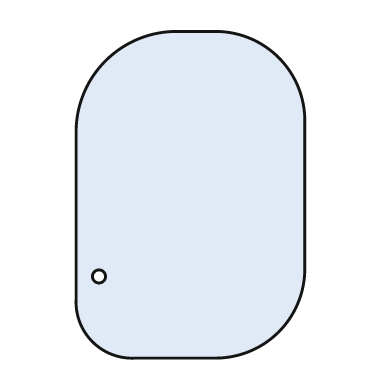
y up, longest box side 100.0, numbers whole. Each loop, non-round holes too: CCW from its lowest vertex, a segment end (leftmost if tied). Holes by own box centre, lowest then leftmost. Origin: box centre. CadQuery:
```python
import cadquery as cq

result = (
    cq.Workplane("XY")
    .moveTo(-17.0, -50.0)
    .lineTo(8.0, -50.0)
    .threePointArc((27.0, -42.0), (35.0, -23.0))
    .lineTo(35.0, 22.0)
    .threePointArc((27.0, 42.0), (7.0, 50.0))
    .lineTo(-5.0, 50.0)
    .threePointArc((-26.0, 41.0), (-35.0, 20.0))
    .lineTo(-35.0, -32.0)
    .threePointArc((-30.0, -45.0), (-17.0, -50.0))
    .close()
    .moveTo(-28.0, -25.0)
    .circle(2.0)
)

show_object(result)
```